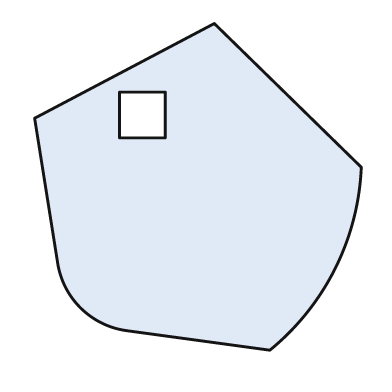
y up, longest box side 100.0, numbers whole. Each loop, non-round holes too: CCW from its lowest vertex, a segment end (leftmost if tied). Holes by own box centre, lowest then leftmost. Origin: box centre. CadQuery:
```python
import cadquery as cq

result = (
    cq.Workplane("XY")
    .moveTo(22.0, -50.0)
    .threePointArc((42.0, -25.0), (50.0, 6.0))
    .lineTo(5.0, 50.0)
    .lineTo(-50.0, 21.0)
    .lineTo(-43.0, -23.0)
    .threePointArc((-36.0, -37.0), (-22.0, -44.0))
    .close()
    .moveTo(-24.0, 15.0)
    .lineTo(-10.0, 15.0)
    .lineTo(-10.0, 29.0)
    .lineTo(-24.0, 29.0)
    .close()
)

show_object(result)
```